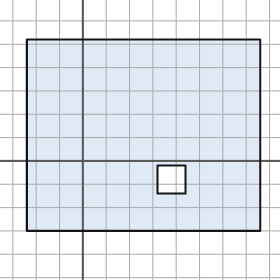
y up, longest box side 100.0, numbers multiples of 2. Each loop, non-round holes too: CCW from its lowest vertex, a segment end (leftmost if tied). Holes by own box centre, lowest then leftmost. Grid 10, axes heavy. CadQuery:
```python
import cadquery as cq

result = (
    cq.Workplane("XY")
    .moveTo(-24.0, -30.0)
    .lineTo(76.0, -30.0)
    .lineTo(76.0, 52.0)
    .lineTo(-24.0, 52.0)
    .close()
    .moveTo(32.0, -14.0)
    .lineTo(44.0, -14.0)
    .lineTo(44.0, -2.0)
    .lineTo(32.0, -2.0)
    .close()
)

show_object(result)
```